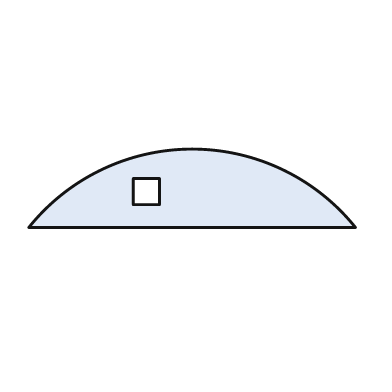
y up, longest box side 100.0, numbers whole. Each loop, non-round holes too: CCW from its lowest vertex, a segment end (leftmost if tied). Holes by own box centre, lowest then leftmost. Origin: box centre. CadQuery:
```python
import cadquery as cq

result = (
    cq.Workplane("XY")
    .moveTo(-50.0, -12.0)
    .lineTo(50.0, -12.0)
    .threePointArc((0.0, 12.0), (-50.0, -12.0))
    .close()
    .moveTo(-18.0, -5.0)
    .lineTo(-10.0, -5.0)
    .lineTo(-10.0, 3.0)
    .lineTo(-18.0, 3.0)
    .close()
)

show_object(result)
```